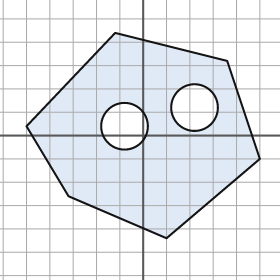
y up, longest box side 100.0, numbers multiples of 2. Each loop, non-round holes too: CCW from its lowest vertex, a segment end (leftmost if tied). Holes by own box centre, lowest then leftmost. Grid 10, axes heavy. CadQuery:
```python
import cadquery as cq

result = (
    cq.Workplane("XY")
    .moveTo(10.0, -44.0)
    .lineTo(50.0, -10.0)
    .lineTo(36.0, 32.0)
    .lineTo(-12.0, 44.0)
    .lineTo(-50.0, 4.0)
    .lineTo(-32.0, -26.0)
    .close()
    .moveTo(-8.0, 4.0)
    .circle(10.0)
    .moveTo(22.0, 12.0)
    .circle(10.0)
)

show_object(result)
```